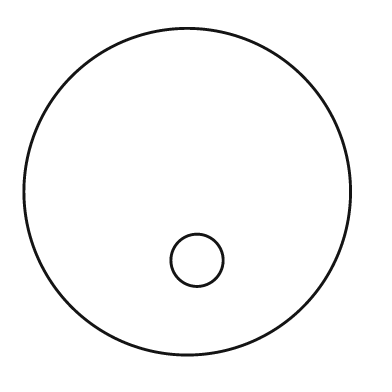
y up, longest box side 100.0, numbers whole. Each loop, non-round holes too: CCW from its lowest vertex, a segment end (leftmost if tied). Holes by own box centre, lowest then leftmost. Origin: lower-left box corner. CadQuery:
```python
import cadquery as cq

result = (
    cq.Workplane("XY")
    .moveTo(50.0, 50.0)
    .circle(50.0)
    .moveTo(53.0, 29.0)
    .circle(8.0)
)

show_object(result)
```